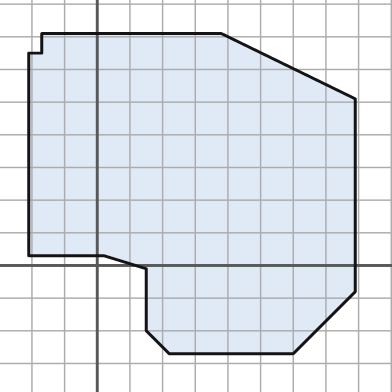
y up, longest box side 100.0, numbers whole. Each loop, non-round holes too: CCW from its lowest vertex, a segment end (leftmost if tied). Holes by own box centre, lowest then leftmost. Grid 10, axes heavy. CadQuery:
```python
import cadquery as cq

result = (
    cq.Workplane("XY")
    .moveTo(22.0, -27.0)
    .lineTo(60.0, -27.0)
    .lineTo(79.0, -8.0)
    .lineTo(79.0, 51.0)
    .lineTo(38.0, 71.0)
    .lineTo(-17.0, 71.0)
    .lineTo(-17.0, 65.0)
    .lineTo(-21.0, 65.0)
    .lineTo(-21.0, 3.0)
    .lineTo(2.0, 3.0)
    .lineTo(15.0, -1.0)
    .lineTo(15.0, -20.0)
    .close()
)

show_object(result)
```